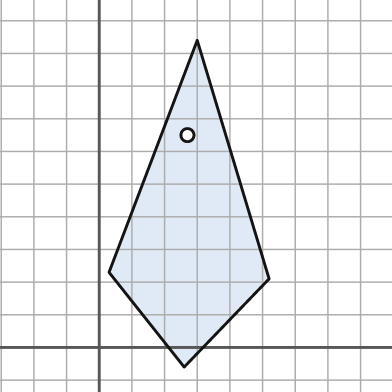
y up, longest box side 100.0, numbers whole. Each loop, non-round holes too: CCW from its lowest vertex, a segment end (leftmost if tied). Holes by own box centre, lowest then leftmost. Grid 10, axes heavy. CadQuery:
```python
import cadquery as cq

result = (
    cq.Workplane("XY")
    .moveTo(26.0, -6.0)
    .lineTo(52.0, 21.0)
    .lineTo(30.0, 94.0)
    .lineTo(3.0, 23.0)
    .close()
    .moveTo(27.0, 65.0)
    .circle(2.0)
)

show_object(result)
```